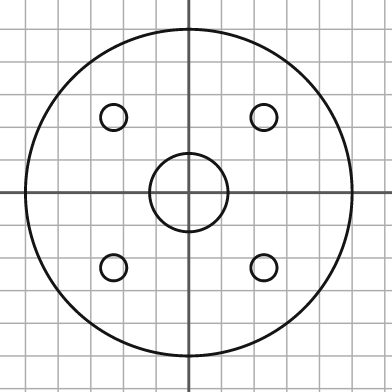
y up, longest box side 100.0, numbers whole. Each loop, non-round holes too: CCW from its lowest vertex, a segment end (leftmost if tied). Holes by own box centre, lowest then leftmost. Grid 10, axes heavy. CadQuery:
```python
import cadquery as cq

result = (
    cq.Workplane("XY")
    .moveTo(0.0, 0.0)
    .circle(50.0)
    .moveTo(-23.0, -23.0)
    .circle(4.0)
    .moveTo(23.0, -23.0)
    .circle(4.0)
    .moveTo(0.0, 0.0)
    .circle(12.0)
    .moveTo(-23.0, 23.0)
    .circle(4.0)
    .moveTo(23.0, 23.0)
    .circle(4.0)
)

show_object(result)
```